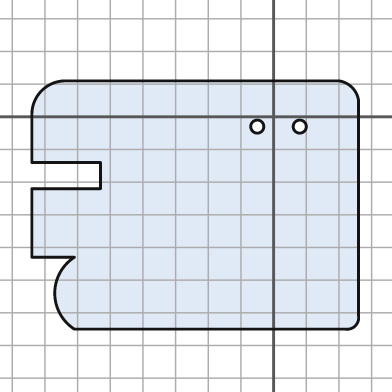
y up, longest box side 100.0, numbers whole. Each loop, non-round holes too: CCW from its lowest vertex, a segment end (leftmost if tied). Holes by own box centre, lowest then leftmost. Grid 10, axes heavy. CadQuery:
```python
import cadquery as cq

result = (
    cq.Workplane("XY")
    .moveTo(-61.0, -65.0)
    .lineTo(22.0, -65.0)
    .threePointArc((25.0, -64.0), (26.0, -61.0))
    .lineTo(26.0, 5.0)
    .threePointArc((24.0, 9.0), (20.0, 11.0))
    .lineTo(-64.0, 11.0)
    .threePointArc((-71.0, 8.0), (-74.0, 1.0))
    .lineTo(-74.0, -14.0)
    .lineTo(-53.0, -14.0)
    .lineTo(-53.0, -22.0)
    .lineTo(-74.0, -22.0)
    .lineTo(-74.0, -43.0)
    .lineTo(-61.0, -43.0)
    .threePointArc((-67.0, -54.0), (-61.0, -65.0))
    .close()
    .moveTo(-5.0, -3.0)
    .circle(2.0)
    .moveTo(8.0, -3.0)
    .circle(2.0)
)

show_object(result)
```